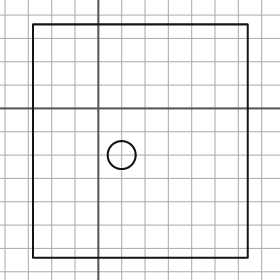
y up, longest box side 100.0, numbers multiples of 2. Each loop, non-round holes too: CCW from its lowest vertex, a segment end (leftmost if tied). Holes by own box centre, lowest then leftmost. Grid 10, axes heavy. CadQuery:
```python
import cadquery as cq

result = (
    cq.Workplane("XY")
    .moveTo(-28.0, -64.0)
    .lineTo(64.0, -64.0)
    .lineTo(64.0, 36.0)
    .lineTo(-28.0, 36.0)
    .close()
    .moveTo(10.0, -20.0)
    .circle(6.0)
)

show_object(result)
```